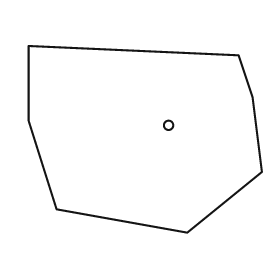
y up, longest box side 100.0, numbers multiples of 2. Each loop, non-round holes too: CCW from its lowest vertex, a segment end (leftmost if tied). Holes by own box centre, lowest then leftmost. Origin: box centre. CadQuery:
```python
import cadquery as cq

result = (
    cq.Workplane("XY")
    .moveTo(18.0, -40.0)
    .lineTo(50.0, -14.0)
    .lineTo(46.0, 18.0)
    .lineTo(40.0, 36.0)
    .lineTo(-50.0, 40.0)
    .lineTo(-50.0, 8.0)
    .lineTo(-38.0, -30.0)
    .close()
    .moveTo(10.0, 6.0)
    .circle(2.0)
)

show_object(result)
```